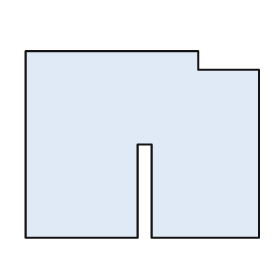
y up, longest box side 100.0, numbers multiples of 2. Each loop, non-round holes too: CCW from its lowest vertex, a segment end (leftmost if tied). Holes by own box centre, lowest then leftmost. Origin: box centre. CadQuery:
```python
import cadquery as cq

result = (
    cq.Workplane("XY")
    .moveTo(-50.0, -40.0)
    .lineTo(-2.0, -40.0)
    .lineTo(-2.0, 0.0)
    .lineTo(4.0, 0.0)
    .lineTo(4.0, -40.0)
    .lineTo(50.0, -40.0)
    .lineTo(50.0, 32.0)
    .lineTo(24.0, 32.0)
    .lineTo(24.0, 40.0)
    .lineTo(-50.0, 40.0)
    .close()
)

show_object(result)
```